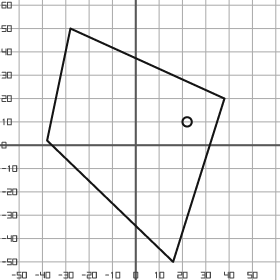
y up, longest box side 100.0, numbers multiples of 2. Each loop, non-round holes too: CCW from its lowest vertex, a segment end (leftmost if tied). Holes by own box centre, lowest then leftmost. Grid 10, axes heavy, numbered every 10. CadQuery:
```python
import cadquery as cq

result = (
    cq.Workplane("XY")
    .moveTo(16.0, -50.0)
    .lineTo(38.0, 20.0)
    .lineTo(-28.0, 50.0)
    .lineTo(-38.0, 2.0)
    .close()
    .moveTo(22.0, 10.0)
    .circle(2.0)
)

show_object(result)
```